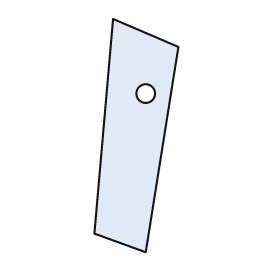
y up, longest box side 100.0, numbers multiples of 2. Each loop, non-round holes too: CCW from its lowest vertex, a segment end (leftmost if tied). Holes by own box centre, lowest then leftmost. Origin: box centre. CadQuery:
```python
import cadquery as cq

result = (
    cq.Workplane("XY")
    .moveTo(4.0, -50.0)
    .lineTo(18.0, 38.0)
    .lineTo(-10.0, 50.0)
    .lineTo(-18.0, -42.0)
    .close()
    .moveTo(4.0, 18.0)
    .circle(4.0)
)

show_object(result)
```